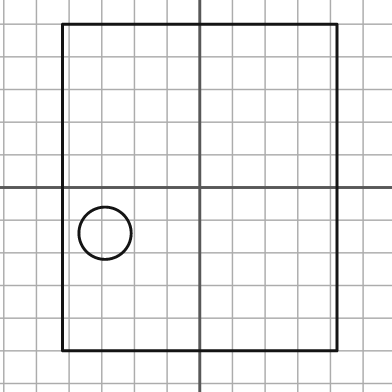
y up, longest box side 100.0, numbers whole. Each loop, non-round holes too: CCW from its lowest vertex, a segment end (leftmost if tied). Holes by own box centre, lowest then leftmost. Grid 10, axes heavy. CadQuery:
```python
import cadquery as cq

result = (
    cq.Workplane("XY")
    .moveTo(-42.0, -50.0)
    .lineTo(42.0, -50.0)
    .lineTo(42.0, 50.0)
    .lineTo(-42.0, 50.0)
    .close()
    .moveTo(-29.0, -14.0)
    .circle(8.0)
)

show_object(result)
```